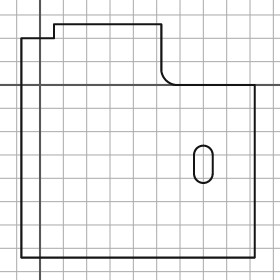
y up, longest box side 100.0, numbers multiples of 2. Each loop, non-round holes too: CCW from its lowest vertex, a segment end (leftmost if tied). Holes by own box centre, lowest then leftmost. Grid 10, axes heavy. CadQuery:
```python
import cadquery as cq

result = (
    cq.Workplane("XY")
    .moveTo(-8.0, -74.0)
    .lineTo(92.0, -74.0)
    .lineTo(92.0, 0.0)
    .lineTo(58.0, 0.0)
    .threePointArc((54.0, 2.0), (52.0, 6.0))
    .lineTo(52.0, 26.0)
    .lineTo(6.0, 26.0)
    .lineTo(6.0, 20.0)
    .lineTo(-8.0, 20.0)
    .close()
    .moveTo(66.0, -38.0)
    .threePointArc((70.0, -42.0), (74.0, -38.0))
    .lineTo(74.0, -30.0)
    .threePointArc((70.0, -26.0), (66.0, -30.0))
    .close()
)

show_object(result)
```